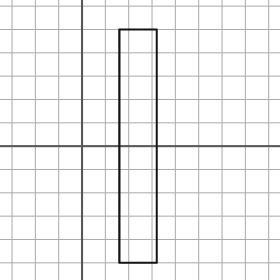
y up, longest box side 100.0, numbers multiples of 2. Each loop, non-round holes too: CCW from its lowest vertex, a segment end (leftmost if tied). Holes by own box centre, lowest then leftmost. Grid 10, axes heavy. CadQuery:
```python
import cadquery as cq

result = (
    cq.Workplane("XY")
    .moveTo(16.0, -50.0)
    .lineTo(32.0, -50.0)
    .lineTo(32.0, 50.0)
    .lineTo(16.0, 50.0)
    .close()
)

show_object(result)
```